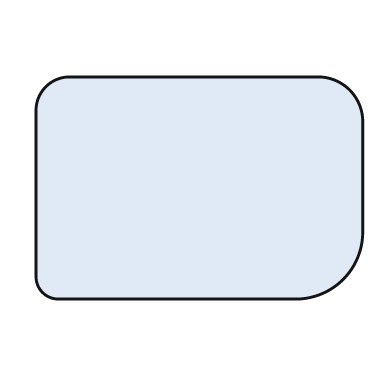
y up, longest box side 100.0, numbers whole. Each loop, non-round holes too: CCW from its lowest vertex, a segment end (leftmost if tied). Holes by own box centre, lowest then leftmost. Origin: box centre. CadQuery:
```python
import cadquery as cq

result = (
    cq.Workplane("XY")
    .moveTo(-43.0, -34.0)
    .lineTo(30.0, -34.0)
    .threePointArc((44.0, -28.0), (50.0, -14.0))
    .lineTo(50.0, 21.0)
    .threePointArc((46.0, 30.0), (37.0, 34.0))
    .lineTo(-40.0, 34.0)
    .threePointArc((-47.0, 31.0), (-50.0, 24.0))
    .lineTo(-50.0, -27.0)
    .threePointArc((-48.0, -32.0), (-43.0, -34.0))
    .close()
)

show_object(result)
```